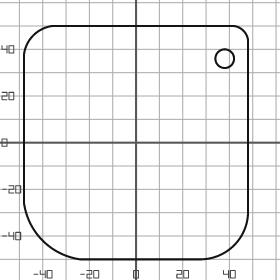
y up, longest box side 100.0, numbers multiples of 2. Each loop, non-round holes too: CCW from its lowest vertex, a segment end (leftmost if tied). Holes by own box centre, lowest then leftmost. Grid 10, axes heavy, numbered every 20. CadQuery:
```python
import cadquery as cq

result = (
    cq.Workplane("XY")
    .moveTo(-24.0, -50.0)
    .lineTo(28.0, -50.0)
    .threePointArc((42.0, -44.0), (48.0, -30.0))
    .lineTo(48.0, 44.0)
    .threePointArc((46.0, 48.0), (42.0, 50.0))
    .lineTo(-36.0, 50.0)
    .threePointArc((-44.0, 46.0), (-48.0, 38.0))
    .lineTo(-48.0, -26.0)
    .threePointArc((-40.0, -42.0), (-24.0, -50.0))
    .close()
    .moveTo(38.0, 36.0)
    .circle(4.0)
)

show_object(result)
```